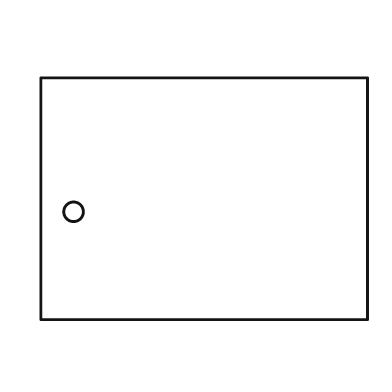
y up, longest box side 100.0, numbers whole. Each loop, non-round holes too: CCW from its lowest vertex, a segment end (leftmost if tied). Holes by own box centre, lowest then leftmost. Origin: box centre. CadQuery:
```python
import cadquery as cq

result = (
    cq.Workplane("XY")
    .moveTo(-50.0, -37.0)
    .lineTo(50.0, -37.0)
    .lineTo(50.0, 37.0)
    .lineTo(-50.0, 37.0)
    .close()
    .moveTo(-40.0, -4.0)
    .circle(3.0)
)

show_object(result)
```